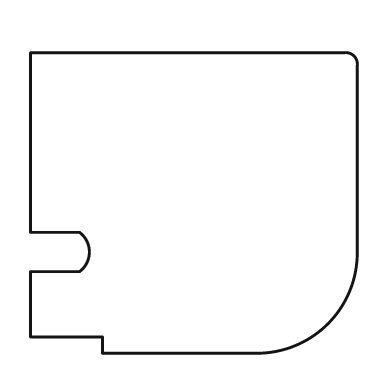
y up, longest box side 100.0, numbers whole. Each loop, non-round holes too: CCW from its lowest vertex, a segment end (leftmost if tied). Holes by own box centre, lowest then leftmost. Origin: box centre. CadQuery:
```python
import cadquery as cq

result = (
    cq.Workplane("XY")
    .moveTo(-28.0, -46.0)
    .lineTo(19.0, -46.0)
    .threePointArc((41.0, -37.0), (50.0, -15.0))
    .lineTo(50.0, 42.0)
    .threePointArc((49.0, 45.0), (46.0, 46.0))
    .lineTo(-50.0, 46.0)
    .lineTo(-50.0, -9.0)
    .lineTo(-35.0, -9.0)
    .threePointArc((-32.0, -15.0), (-35.0, -21.0))
    .lineTo(-50.0, -21.0)
    .lineTo(-50.0, -41.0)
    .lineTo(-28.0, -41.0)
    .close()
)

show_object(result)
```